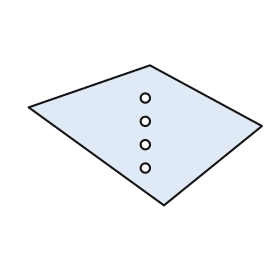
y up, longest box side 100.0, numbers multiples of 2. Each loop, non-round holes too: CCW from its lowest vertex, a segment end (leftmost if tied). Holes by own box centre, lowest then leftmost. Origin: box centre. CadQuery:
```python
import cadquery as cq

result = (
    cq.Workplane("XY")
    .moveTo(8.0, -30.0)
    .lineTo(50.0, 4.0)
    .lineTo(2.0, 30.0)
    .lineTo(-50.0, 12.0)
    .close()
    .moveTo(0.0, -14.0)
    .circle(2.0)
    .moveTo(0.0, -4.0)
    .circle(2.0)
    .moveTo(0.0, 6.0)
    .circle(2.0)
    .moveTo(0.0, 16.0)
    .circle(2.0)
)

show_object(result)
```